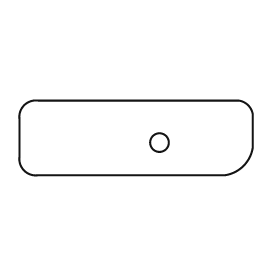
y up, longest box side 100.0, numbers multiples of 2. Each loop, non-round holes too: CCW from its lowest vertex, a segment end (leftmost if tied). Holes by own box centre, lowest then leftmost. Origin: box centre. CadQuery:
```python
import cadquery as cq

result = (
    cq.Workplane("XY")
    .moveTo(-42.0, -16.0)
    .lineTo(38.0, -16.0)
    .threePointArc((46.0, -12.0), (50.0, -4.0))
    .lineTo(50.0, 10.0)
    .threePointArc((48.0, 14.0), (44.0, 16.0))
    .lineTo(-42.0, 16.0)
    .threePointArc((-48.0, 14.0), (-50.0, 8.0))
    .lineTo(-50.0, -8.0)
    .threePointArc((-48.0, -14.0), (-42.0, -16.0))
    .close()
    .moveTo(10.0, -2.0)
    .circle(4.0)
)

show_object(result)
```